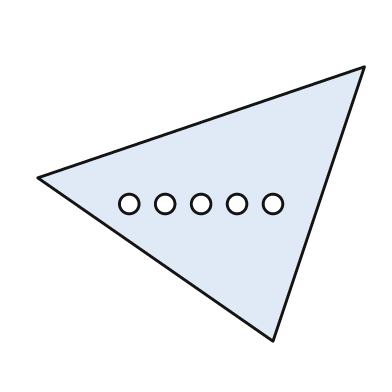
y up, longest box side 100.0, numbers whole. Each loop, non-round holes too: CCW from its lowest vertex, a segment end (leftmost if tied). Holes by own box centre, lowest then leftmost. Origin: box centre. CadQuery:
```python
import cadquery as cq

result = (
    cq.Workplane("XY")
    .moveTo(22.0, -42.0)
    .lineTo(50.0, 42.0)
    .lineTo(-50.0, 8.0)
    .close()
    .moveTo(-22.0, 0.0)
    .circle(3.0)
    .moveTo(-11.0, 0.0)
    .circle(3.0)
    .moveTo(0.0, 0.0)
    .circle(3.0)
    .moveTo(11.0, 0.0)
    .circle(3.0)
    .moveTo(22.0, 0.0)
    .circle(3.0)
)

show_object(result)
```